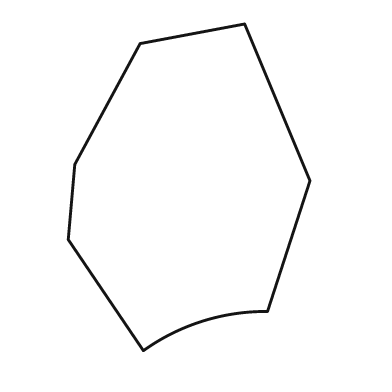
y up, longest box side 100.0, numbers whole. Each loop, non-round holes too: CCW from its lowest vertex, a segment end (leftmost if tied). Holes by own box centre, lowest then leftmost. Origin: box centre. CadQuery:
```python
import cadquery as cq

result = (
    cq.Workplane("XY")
    .moveTo(-14.0, -50.0)
    .threePointArc((4.0, -41.0), (24.0, -38.0))
    .lineTo(37.0, 2.0)
    .lineTo(17.0, 50.0)
    .lineTo(-15.0, 44.0)
    .lineTo(-35.0, 7.0)
    .lineTo(-37.0, -16.0)
    .close()
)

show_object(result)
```